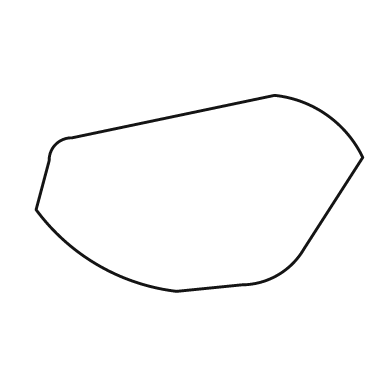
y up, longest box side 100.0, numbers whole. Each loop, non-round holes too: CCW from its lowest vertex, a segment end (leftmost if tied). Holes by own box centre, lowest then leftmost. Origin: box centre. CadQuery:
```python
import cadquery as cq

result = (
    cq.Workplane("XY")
    .moveTo(-7.0, -30.0)
    .lineTo(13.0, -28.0)
    .threePointArc((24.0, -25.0), (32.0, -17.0))
    .lineTo(50.0, 11.0)
    .threePointArc((39.0, 24.0), (23.0, 30.0))
    .lineTo(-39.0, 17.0)
    .threePointArc((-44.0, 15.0), (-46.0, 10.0))
    .lineTo(-50.0, -5.0)
    .threePointArc((-31.0, -22.0), (-7.0, -30.0))
    .close()
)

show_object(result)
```